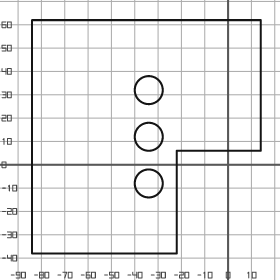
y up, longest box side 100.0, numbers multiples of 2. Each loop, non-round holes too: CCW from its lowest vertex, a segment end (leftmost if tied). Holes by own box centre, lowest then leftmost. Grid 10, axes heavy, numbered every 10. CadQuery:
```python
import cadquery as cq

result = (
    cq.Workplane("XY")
    .moveTo(-84.0, -38.0)
    .lineTo(-22.0, -38.0)
    .lineTo(-22.0, 6.0)
    .lineTo(14.0, 6.0)
    .lineTo(14.0, 62.0)
    .lineTo(-84.0, 62.0)
    .close()
    .moveTo(-34.0, -8.0)
    .circle(6.0)
    .moveTo(-34.0, 12.0)
    .circle(6.0)
    .moveTo(-34.0, 32.0)
    .circle(6.0)
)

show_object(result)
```